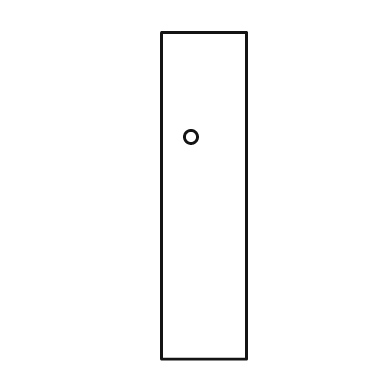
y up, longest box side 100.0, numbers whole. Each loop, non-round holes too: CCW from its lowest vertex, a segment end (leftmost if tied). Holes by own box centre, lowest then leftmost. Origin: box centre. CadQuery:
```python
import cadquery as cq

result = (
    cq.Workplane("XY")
    .moveTo(-13.0, -50.0)
    .lineTo(13.0, -50.0)
    .lineTo(13.0, 50.0)
    .lineTo(-13.0, 50.0)
    .close()
    .moveTo(-4.0, 18.0)
    .circle(2.0)
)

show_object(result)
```